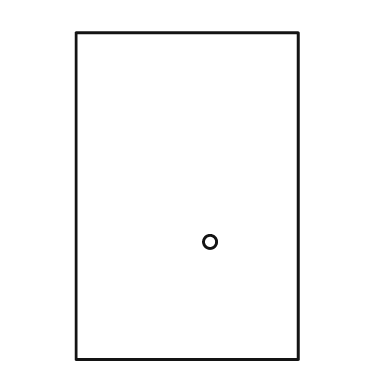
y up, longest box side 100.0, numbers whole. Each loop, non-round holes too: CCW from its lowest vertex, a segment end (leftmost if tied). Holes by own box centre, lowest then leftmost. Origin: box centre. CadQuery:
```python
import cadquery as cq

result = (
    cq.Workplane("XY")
    .moveTo(-34.0, -50.0)
    .lineTo(34.0, -50.0)
    .lineTo(34.0, 50.0)
    .lineTo(-34.0, 50.0)
    .close()
    .moveTo(7.0, -14.0)
    .circle(2.0)
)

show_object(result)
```